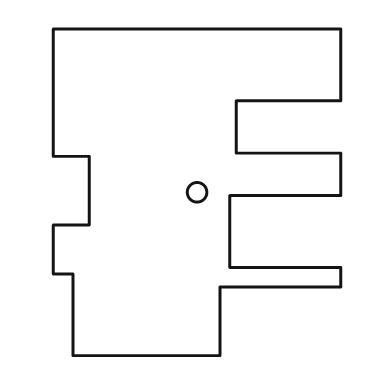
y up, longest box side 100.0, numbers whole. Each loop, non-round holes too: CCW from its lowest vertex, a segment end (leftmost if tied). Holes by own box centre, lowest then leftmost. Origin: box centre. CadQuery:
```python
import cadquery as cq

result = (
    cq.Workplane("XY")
    .moveTo(-38.0, -50.0)
    .lineTo(7.0, -50.0)
    .lineTo(7.0, -29.0)
    .lineTo(44.0, -29.0)
    .lineTo(44.0, -23.0)
    .lineTo(10.0, -23.0)
    .lineTo(10.0, -1.0)
    .lineTo(44.0, -1.0)
    .lineTo(44.0, 12.0)
    .lineTo(12.0, 12.0)
    .lineTo(12.0, 28.0)
    .lineTo(44.0, 28.0)
    .lineTo(44.0, 50.0)
    .lineTo(-44.0, 50.0)
    .lineTo(-44.0, 11.0)
    .lineTo(-33.0, 11.0)
    .lineTo(-33.0, -10.0)
    .lineTo(-44.0, -10.0)
    .lineTo(-44.0, -25.0)
    .lineTo(-38.0, -25.0)
    .close()
    .moveTo(0.0, 0.0)
    .circle(3.0)
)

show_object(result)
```